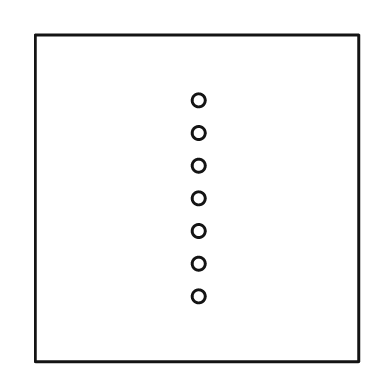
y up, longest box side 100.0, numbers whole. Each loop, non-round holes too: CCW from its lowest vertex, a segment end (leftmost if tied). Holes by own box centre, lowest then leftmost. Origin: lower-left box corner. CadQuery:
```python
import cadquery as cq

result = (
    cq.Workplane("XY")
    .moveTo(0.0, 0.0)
    .lineTo(99.0, 0.0)
    .lineTo(99.0, 100.0)
    .lineTo(0.0, 100.0)
    .close()
    .moveTo(50.0, 20.0)
    .circle(2.0)
    .moveTo(50.0, 30.0)
    .circle(2.0)
    .moveTo(50.0, 40.0)
    .circle(2.0)
    .moveTo(50.0, 50.0)
    .circle(2.0)
    .moveTo(50.0, 60.0)
    .circle(2.0)
    .moveTo(50.0, 70.0)
    .circle(2.0)
    .moveTo(50.0, 80.0)
    .circle(2.0)
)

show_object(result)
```